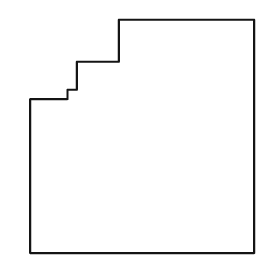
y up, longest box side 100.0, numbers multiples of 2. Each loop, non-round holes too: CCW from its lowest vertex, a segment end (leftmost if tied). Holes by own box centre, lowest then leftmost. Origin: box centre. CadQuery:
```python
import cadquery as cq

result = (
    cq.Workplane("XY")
    .moveTo(-48.0, -50.0)
    .lineTo(48.0, -50.0)
    .lineTo(48.0, 50.0)
    .lineTo(-10.0, 50.0)
    .lineTo(-10.0, 32.0)
    .lineTo(-28.0, 32.0)
    .lineTo(-28.0, 20.0)
    .lineTo(-32.0, 20.0)
    .lineTo(-32.0, 16.0)
    .lineTo(-48.0, 16.0)
    .close()
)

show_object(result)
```